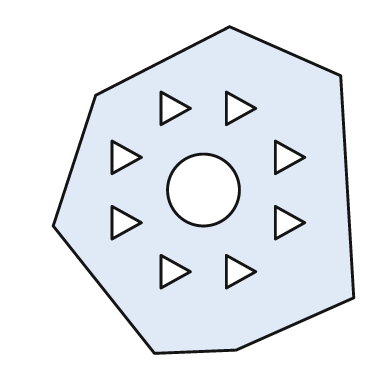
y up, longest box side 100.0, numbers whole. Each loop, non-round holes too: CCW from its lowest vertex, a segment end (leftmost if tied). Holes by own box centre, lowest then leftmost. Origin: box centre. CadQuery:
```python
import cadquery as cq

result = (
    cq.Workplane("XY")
    .moveTo(-15.0, -50.0)
    .lineTo(10.0, -49.0)
    .lineTo(46.0, -33.0)
    .lineTo(42.0, 35.0)
    .lineTo(8.0, 50.0)
    .lineTo(-33.0, 29.0)
    .lineTo(-46.0, -11.0)
    .close()
    .moveTo(-13.0, -30.0)
    .lineTo(-4.0, -25.0)
    .lineTo(-13.0, -20.0)
    .close()
    .moveTo(7.0, -30.0)
    .lineTo(16.0, -25.0)
    .lineTo(7.0, -20.0)
    .close()
    .moveTo(-28.0, -15.0)
    .lineTo(-19.0, -10.0)
    .lineTo(-28.0, -5.0)
    .close()
    .moveTo(22.0, -15.0)
    .lineTo(31.0, -10.0)
    .lineTo(22.0, -5.0)
    .close()
    .moveTo(0.0, 0.0)
    .circle(11.0)
    .moveTo(-28.0, 5.0)
    .lineTo(-19.0, 10.0)
    .lineTo(-28.0, 15.0)
    .close()
    .moveTo(22.0, 5.0)
    .lineTo(31.0, 10.0)
    .lineTo(22.0, 15.0)
    .close()
    .moveTo(-13.0, 20.0)
    .lineTo(-4.0, 25.0)
    .lineTo(-13.0, 30.0)
    .close()
    .moveTo(7.0, 20.0)
    .lineTo(16.0, 25.0)
    .lineTo(7.0, 30.0)
    .close()
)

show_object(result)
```